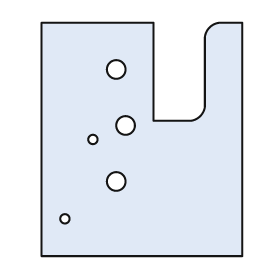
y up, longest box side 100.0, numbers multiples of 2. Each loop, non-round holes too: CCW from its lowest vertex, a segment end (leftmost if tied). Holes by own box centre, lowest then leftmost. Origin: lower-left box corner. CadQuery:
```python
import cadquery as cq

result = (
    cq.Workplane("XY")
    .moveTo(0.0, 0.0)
    .lineTo(86.0, 0.0)
    .lineTo(86.0, 100.0)
    .lineTo(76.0, 100.0)
    .threePointArc((72.0, 98.0), (70.0, 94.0))
    .lineTo(70.0, 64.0)
    .threePointArc((68.0, 60.0), (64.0, 58.0))
    .lineTo(48.0, 58.0)
    .lineTo(48.0, 100.0)
    .lineTo(0.0, 100.0)
    .close()
    .moveTo(10.0, 16.0)
    .circle(2.0)
    .moveTo(32.0, 32.0)
    .circle(4.0)
    .moveTo(22.0, 50.0)
    .circle(2.0)
    .moveTo(36.0, 56.0)
    .circle(4.0)
    .moveTo(32.0, 80.0)
    .circle(4.0)
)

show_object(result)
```